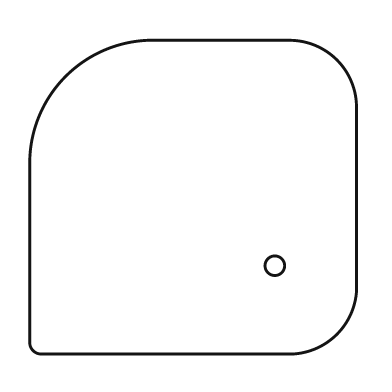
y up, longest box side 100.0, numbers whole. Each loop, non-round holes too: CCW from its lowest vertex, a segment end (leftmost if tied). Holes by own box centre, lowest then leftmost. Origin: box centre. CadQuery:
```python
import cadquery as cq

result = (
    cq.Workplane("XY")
    .moveTo(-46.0, -48.0)
    .lineTo(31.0, -48.0)
    .threePointArc((44.0, -42.0), (50.0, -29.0))
    .lineTo(50.0, 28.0)
    .threePointArc((44.0, 42.0), (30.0, 48.0))
    .lineTo(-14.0, 48.0)
    .threePointArc((-39.0, 37.0), (-50.0, 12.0))
    .lineTo(-50.0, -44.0)
    .threePointArc((-49.0, -47.0), (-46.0, -48.0))
    .close()
    .moveTo(25.0, -21.0)
    .circle(3.0)
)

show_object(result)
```